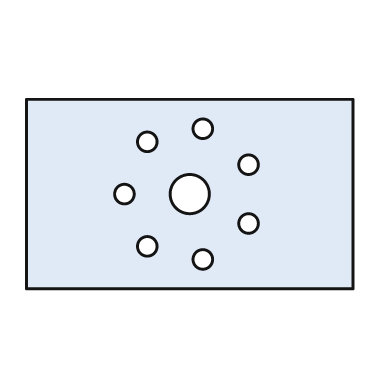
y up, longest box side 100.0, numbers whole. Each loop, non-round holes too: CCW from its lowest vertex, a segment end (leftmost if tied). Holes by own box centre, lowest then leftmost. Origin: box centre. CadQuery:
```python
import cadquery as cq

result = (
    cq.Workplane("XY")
    .moveTo(-50.0, -29.0)
    .lineTo(50.0, -29.0)
    .lineTo(50.0, 29.0)
    .lineTo(-50.0, 29.0)
    .close()
    .moveTo(4.0, -20.0)
    .circle(3.0)
    .moveTo(-13.0, -16.0)
    .circle(3.0)
    .moveTo(18.0, -9.0)
    .circle(3.0)
    .moveTo(-20.0, 0.0)
    .circle(3.0)
    .moveTo(0.0, 0.0)
    .circle(6.0)
    .moveTo(18.0, 9.0)
    .circle(3.0)
    .moveTo(-13.0, 16.0)
    .circle(3.0)
    .moveTo(4.0, 20.0)
    .circle(3.0)
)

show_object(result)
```